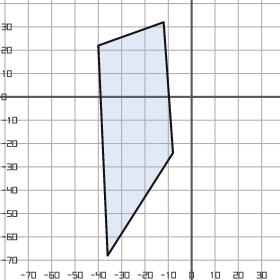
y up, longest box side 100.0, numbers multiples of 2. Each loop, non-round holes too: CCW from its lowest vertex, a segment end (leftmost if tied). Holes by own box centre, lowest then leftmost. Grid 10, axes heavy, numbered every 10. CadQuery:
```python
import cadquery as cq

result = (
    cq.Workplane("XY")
    .moveTo(-36.0, -68.0)
    .lineTo(-8.0, -24.0)
    .lineTo(-12.0, 32.0)
    .lineTo(-40.0, 22.0)
    .close()
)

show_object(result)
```